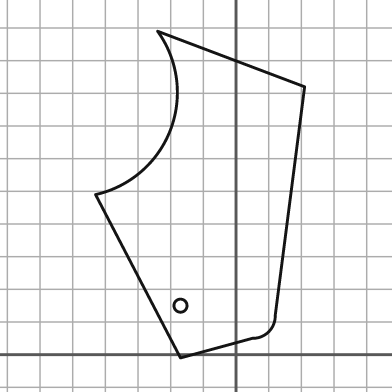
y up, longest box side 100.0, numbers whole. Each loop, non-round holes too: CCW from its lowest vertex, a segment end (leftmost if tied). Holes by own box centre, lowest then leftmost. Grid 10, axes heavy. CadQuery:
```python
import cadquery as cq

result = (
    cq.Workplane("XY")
    .moveTo(-17.0, -1.0)
    .lineTo(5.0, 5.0)
    .threePointArc((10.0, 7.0), (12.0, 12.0))
    .lineTo(21.0, 82.0)
    .lineTo(-24.0, 99.0)
    .threePointArc((-20.0, 69.0), (-43.0, 49.0))
    .close()
    .moveTo(-17.0, 15.0)
    .circle(2.0)
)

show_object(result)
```